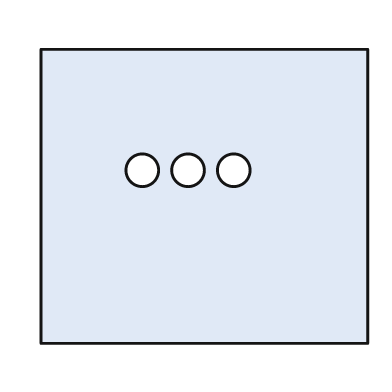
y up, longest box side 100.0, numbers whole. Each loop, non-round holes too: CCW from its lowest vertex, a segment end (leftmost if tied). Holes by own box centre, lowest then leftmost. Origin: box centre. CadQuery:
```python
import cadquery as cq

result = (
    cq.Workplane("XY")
    .moveTo(-50.0, -45.0)
    .lineTo(50.0, -45.0)
    .lineTo(50.0, 45.0)
    .lineTo(-50.0, 45.0)
    .close()
    .moveTo(-19.0, 8.0)
    .circle(5.0)
    .moveTo(-5.0, 8.0)
    .circle(5.0)
    .moveTo(9.0, 8.0)
    .circle(5.0)
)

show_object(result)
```